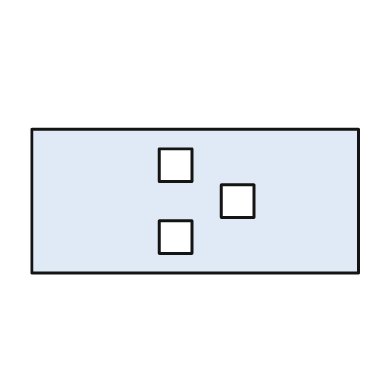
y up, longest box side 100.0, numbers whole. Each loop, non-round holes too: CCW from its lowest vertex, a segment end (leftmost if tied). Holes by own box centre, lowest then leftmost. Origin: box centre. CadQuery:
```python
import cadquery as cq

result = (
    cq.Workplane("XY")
    .moveTo(-50.0, -22.0)
    .lineTo(50.0, -22.0)
    .lineTo(50.0, 22.0)
    .lineTo(-50.0, 22.0)
    .close()
    .moveTo(-11.0, -16.0)
    .lineTo(-1.0, -16.0)
    .lineTo(-1.0, -6.0)
    .lineTo(-11.0, -6.0)
    .close()
    .moveTo(8.0, -5.0)
    .lineTo(18.0, -5.0)
    .lineTo(18.0, 5.0)
    .lineTo(8.0, 5.0)
    .close()
    .moveTo(-11.0, 6.0)
    .lineTo(-1.0, 6.0)
    .lineTo(-1.0, 16.0)
    .lineTo(-11.0, 16.0)
    .close()
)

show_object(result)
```